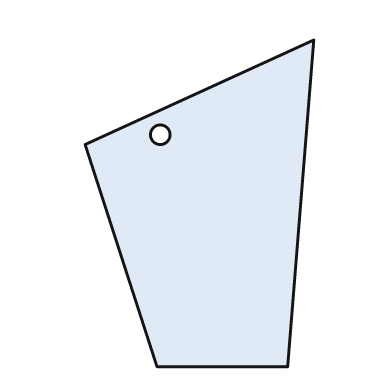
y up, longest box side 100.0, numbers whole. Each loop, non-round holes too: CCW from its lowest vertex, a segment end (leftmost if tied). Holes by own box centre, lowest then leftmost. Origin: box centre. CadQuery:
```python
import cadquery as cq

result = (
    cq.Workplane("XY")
    .moveTo(-13.0, -50.0)
    .lineTo(27.0, -50.0)
    .lineTo(35.0, 50.0)
    .lineTo(-35.0, 18.0)
    .close()
    .moveTo(-12.0, 21.0)
    .circle(3.0)
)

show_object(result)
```